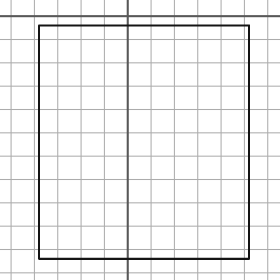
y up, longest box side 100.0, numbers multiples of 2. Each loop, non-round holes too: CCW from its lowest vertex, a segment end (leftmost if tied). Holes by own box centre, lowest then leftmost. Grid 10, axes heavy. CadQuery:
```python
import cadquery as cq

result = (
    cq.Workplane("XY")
    .moveTo(-38.0, -104.0)
    .lineTo(52.0, -104.0)
    .lineTo(52.0, -4.0)
    .lineTo(-38.0, -4.0)
    .close()
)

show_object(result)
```